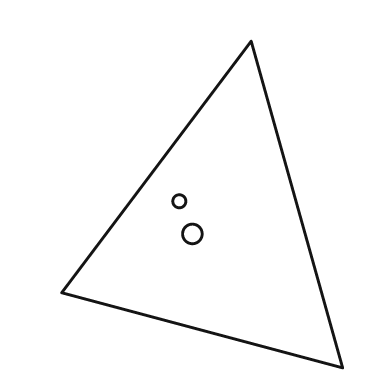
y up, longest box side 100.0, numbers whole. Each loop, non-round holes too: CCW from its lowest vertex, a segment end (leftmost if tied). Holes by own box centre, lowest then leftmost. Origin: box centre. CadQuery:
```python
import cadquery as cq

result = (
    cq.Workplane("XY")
    .moveTo(43.0, -50.0)
    .lineTo(15.0, 50.0)
    .lineTo(-43.0, -27.0)
    .close()
    .moveTo(-3.0, -9.0)
    .circle(3.0)
    .moveTo(-7.0, 1.0)
    .circle(2.0)
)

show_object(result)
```